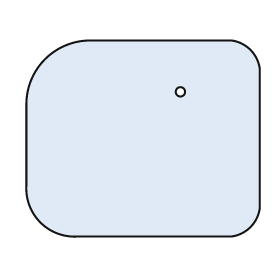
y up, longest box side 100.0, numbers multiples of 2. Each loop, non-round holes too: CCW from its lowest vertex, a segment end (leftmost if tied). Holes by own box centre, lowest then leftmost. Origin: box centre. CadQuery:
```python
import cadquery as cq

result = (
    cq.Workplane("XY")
    .moveTo(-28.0, -42.0)
    .lineTo(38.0, -42.0)
    .threePointArc((46.0, -38.0), (50.0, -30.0))
    .lineTo(50.0, 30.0)
    .threePointArc((46.0, 38.0), (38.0, 42.0))
    .lineTo(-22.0, 42.0)
    .threePointArc((-42.0, 34.0), (-50.0, 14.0))
    .lineTo(-50.0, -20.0)
    .threePointArc((-44.0, -36.0), (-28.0, -42.0))
    .close()
    .moveTo(16.0, 20.0)
    .circle(2.0)
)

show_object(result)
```